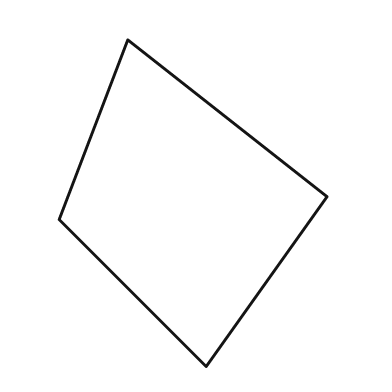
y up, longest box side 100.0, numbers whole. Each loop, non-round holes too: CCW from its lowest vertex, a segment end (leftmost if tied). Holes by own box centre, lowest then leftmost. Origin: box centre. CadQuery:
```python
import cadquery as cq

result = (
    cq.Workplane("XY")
    .moveTo(4.0, -50.0)
    .lineTo(41.0, 2.0)
    .lineTo(-20.0, 50.0)
    .lineTo(-41.0, -5.0)
    .close()
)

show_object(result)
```